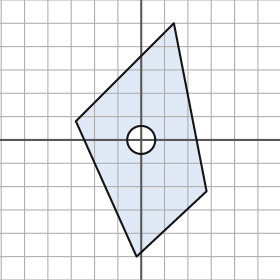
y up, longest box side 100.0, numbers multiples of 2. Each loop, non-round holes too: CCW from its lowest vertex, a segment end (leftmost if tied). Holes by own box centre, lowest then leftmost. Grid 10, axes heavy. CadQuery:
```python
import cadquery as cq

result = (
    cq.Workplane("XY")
    .moveTo(-2.0, -50.0)
    .lineTo(28.0, -22.0)
    .lineTo(14.0, 50.0)
    .lineTo(-28.0, 8.0)
    .close()
    .moveTo(0.0, 0.0)
    .circle(6.0)
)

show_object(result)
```